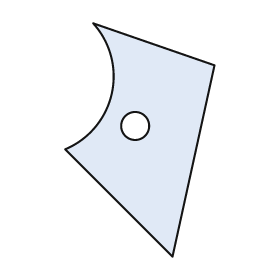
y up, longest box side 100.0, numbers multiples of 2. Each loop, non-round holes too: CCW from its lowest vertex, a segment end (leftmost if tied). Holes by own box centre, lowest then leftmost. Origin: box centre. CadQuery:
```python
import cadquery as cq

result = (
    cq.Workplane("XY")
    .moveTo(14.0, -50.0)
    .lineTo(32.0, 32.0)
    .lineTo(-20.0, 50.0)
    .threePointArc((-12.0, 20.0), (-32.0, -4.0))
    .close()
    .moveTo(-2.0, 6.0)
    .circle(6.0)
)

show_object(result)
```